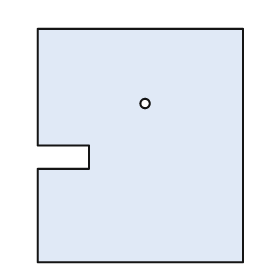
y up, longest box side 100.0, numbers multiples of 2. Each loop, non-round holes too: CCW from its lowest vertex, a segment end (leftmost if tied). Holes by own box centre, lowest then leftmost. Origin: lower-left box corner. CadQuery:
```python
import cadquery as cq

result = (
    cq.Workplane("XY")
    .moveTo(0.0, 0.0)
    .lineTo(88.0, 0.0)
    .lineTo(88.0, 100.0)
    .lineTo(0.0, 100.0)
    .lineTo(0.0, 50.0)
    .lineTo(22.0, 50.0)
    .lineTo(22.0, 40.0)
    .lineTo(0.0, 40.0)
    .close()
    .moveTo(46.0, 68.0)
    .circle(2.0)
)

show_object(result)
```